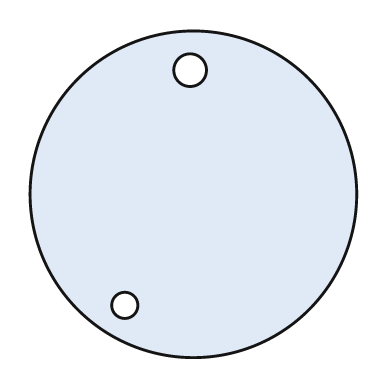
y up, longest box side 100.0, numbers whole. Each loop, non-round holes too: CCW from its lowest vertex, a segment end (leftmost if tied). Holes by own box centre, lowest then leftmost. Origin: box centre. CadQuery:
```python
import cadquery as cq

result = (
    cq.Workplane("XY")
    .moveTo(0.0, 0.0)
    .circle(50.0)
    .moveTo(-21.0, -34.0)
    .circle(4.0)
    .moveTo(-1.0, 38.0)
    .circle(5.0)
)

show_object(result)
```